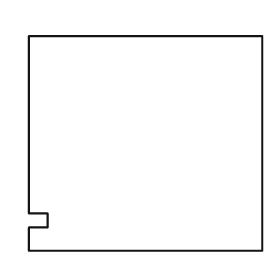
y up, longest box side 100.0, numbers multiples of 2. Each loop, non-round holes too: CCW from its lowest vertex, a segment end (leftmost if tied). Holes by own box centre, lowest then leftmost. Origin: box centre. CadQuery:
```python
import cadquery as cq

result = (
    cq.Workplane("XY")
    .moveTo(-50.0, -46.0)
    .lineTo(50.0, -46.0)
    .lineTo(50.0, 46.0)
    .lineTo(-50.0, 46.0)
    .lineTo(-50.0, -30.0)
    .lineTo(-42.0, -30.0)
    .lineTo(-42.0, -36.0)
    .lineTo(-50.0, -36.0)
    .close()
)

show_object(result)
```